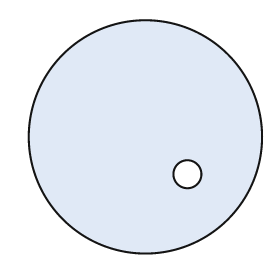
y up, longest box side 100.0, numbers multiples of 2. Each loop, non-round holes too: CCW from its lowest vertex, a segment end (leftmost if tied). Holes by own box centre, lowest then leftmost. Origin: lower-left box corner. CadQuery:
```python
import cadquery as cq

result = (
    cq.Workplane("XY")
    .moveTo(50.0, 50.0)
    .circle(50.0)
    .moveTo(68.0, 34.0)
    .circle(6.0)
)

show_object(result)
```